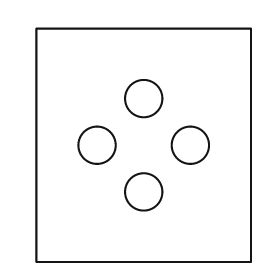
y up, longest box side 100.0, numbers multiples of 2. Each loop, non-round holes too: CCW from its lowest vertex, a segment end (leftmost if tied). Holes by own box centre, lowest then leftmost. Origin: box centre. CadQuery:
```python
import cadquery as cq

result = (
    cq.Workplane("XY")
    .moveTo(-46.0, -50.0)
    .lineTo(46.0, -50.0)
    .lineTo(46.0, 50.0)
    .lineTo(-46.0, 50.0)
    .close()
    .moveTo(0.0, -20.0)
    .circle(8.0)
    .moveTo(-20.0, 0.0)
    .circle(8.0)
    .moveTo(20.0, 0.0)
    .circle(8.0)
    .moveTo(0.0, 20.0)
    .circle(8.0)
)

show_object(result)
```